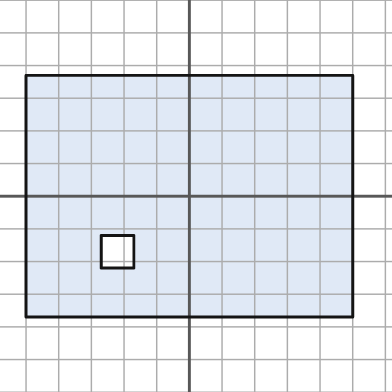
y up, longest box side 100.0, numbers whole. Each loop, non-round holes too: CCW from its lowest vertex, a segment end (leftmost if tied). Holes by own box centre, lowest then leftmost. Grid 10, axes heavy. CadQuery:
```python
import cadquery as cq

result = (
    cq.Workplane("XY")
    .moveTo(-50.0, -37.0)
    .lineTo(50.0, -37.0)
    .lineTo(50.0, 37.0)
    .lineTo(-50.0, 37.0)
    .close()
    .moveTo(-27.0, -22.0)
    .lineTo(-17.0, -22.0)
    .lineTo(-17.0, -12.0)
    .lineTo(-27.0, -12.0)
    .close()
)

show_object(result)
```